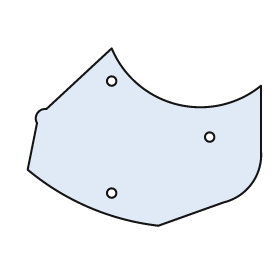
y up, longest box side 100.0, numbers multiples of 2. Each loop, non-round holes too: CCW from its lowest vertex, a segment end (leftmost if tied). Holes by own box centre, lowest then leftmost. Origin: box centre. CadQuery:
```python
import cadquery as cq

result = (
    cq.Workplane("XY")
    .moveTo(6.0, -38.0)
    .lineTo(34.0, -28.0)
    .threePointArc((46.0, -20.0), (50.0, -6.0))
    .lineTo(50.0, 22.0)
    .threePointArc((14.0, 14.0), (-14.0, 38.0))
    .lineTo(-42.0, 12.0)
    .threePointArc((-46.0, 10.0), (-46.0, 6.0))
    .lineTo(-50.0, -14.0)
    .threePointArc((-24.0, -30.0), (6.0, -38.0))
    .close()
    .moveTo(-14.0, -24.0)
    .circle(2.0)
    .moveTo(28.0, 0.0)
    .circle(2.0)
    .moveTo(-14.0, 24.0)
    .circle(2.0)
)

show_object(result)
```